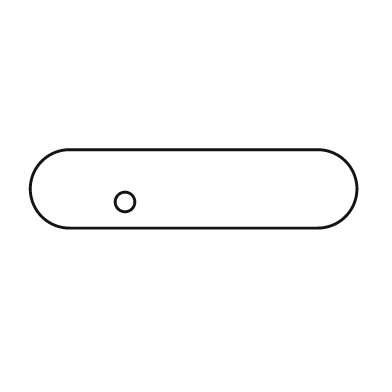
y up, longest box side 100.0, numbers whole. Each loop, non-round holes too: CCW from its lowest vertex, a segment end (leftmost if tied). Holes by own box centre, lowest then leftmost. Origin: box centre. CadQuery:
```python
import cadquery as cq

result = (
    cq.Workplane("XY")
    .moveTo(-38.0, -12.0)
    .lineTo(38.0, -12.0)
    .threePointArc((50.0, 0.0), (38.0, 12.0))
    .lineTo(-38.0, 12.0)
    .threePointArc((-50.0, 0.0), (-38.0, -12.0))
    .close()
    .moveTo(-21.0, -4.0)
    .circle(3.0)
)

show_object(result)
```